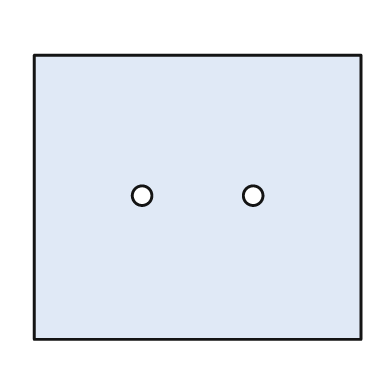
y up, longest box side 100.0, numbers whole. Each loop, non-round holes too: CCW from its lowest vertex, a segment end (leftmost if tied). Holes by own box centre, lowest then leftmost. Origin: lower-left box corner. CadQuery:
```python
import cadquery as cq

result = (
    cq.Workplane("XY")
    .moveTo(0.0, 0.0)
    .lineTo(100.0, 0.0)
    .lineTo(100.0, 87.0)
    .lineTo(0.0, 87.0)
    .close()
    .moveTo(33.0, 44.0)
    .circle(3.0)
    .moveTo(67.0, 44.0)
    .circle(3.0)
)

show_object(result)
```